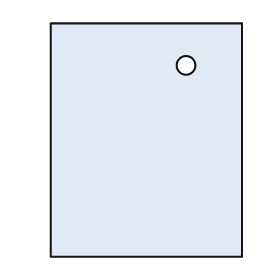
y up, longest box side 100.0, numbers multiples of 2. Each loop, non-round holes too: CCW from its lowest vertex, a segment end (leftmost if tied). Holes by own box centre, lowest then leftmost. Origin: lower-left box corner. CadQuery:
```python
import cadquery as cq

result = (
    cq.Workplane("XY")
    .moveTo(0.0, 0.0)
    .lineTo(82.0, 0.0)
    .lineTo(82.0, 100.0)
    .lineTo(0.0, 100.0)
    .close()
    .moveTo(58.0, 82.0)
    .circle(4.0)
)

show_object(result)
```